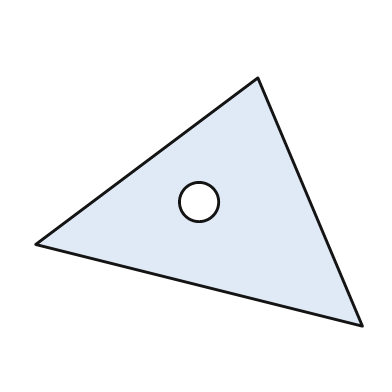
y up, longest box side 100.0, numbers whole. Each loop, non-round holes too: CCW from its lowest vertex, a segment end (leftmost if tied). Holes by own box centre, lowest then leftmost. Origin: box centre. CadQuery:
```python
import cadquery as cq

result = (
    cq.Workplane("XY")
    .moveTo(50.0, -38.0)
    .lineTo(18.0, 38.0)
    .lineTo(-50.0, -13.0)
    .close()
    .moveTo(0.0, 0.0)
    .circle(6.0)
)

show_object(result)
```